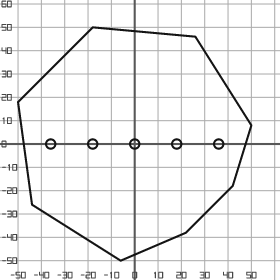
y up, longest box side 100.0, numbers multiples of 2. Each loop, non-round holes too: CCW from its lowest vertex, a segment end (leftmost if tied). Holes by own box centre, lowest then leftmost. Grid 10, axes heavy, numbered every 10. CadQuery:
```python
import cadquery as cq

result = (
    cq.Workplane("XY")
    .moveTo(-6.0, -50.0)
    .lineTo(22.0, -38.0)
    .lineTo(42.0, -18.0)
    .lineTo(50.0, 8.0)
    .lineTo(26.0, 46.0)
    .lineTo(-18.0, 50.0)
    .lineTo(-50.0, 18.0)
    .lineTo(-44.0, -26.0)
    .close()
    .moveTo(-36.0, 0.0)
    .circle(2.0)
    .moveTo(-18.0, 0.0)
    .circle(2.0)
    .moveTo(0.0, 0.0)
    .circle(2.0)
    .moveTo(18.0, 0.0)
    .circle(2.0)
    .moveTo(36.0, 0.0)
    .circle(2.0)
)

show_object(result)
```